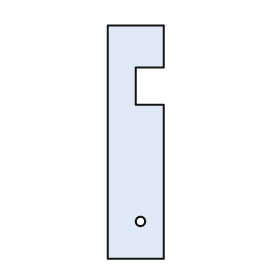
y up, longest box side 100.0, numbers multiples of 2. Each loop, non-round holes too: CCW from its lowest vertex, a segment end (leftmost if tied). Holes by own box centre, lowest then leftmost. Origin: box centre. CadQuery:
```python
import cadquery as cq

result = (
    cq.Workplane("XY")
    .moveTo(-12.0, -50.0)
    .lineTo(12.0, -50.0)
    .lineTo(12.0, 16.0)
    .lineTo(0.0, 16.0)
    .lineTo(0.0, 32.0)
    .lineTo(12.0, 32.0)
    .lineTo(12.0, 50.0)
    .lineTo(-12.0, 50.0)
    .close()
    .moveTo(2.0, -34.0)
    .circle(2.0)
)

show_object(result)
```